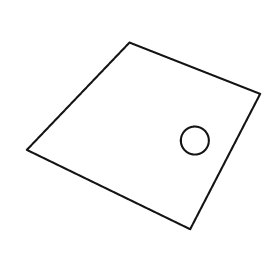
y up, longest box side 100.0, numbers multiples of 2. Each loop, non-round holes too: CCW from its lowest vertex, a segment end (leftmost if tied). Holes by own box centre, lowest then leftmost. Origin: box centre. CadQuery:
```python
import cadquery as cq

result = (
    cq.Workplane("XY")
    .moveTo(20.0, -40.0)
    .lineTo(50.0, 18.0)
    .lineTo(-6.0, 40.0)
    .lineTo(-50.0, -6.0)
    .close()
    .moveTo(22.0, -2.0)
    .circle(6.0)
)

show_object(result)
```